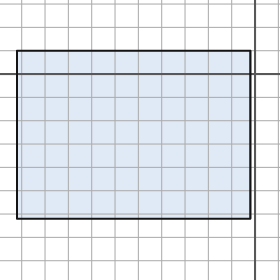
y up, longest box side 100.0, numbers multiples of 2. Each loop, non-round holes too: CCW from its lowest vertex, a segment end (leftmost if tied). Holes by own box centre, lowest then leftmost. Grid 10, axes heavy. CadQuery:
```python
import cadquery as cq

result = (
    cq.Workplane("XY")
    .moveTo(-102.0, -62.0)
    .lineTo(-2.0, -62.0)
    .lineTo(-2.0, 10.0)
    .lineTo(-102.0, 10.0)
    .close()
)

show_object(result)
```